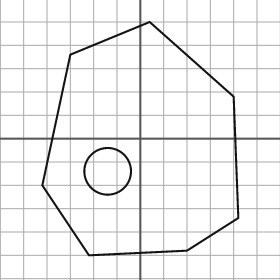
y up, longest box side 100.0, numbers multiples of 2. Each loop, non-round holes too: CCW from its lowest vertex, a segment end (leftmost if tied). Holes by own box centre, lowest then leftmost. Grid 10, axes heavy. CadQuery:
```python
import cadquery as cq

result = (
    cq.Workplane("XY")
    .moveTo(-22.0, -50.0)
    .lineTo(20.0, -48.0)
    .lineTo(42.0, -34.0)
    .lineTo(40.0, 18.0)
    .lineTo(4.0, 50.0)
    .lineTo(-30.0, 36.0)
    .lineTo(-42.0, -20.0)
    .close()
    .moveTo(-14.0, -14.0)
    .circle(10.0)
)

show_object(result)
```